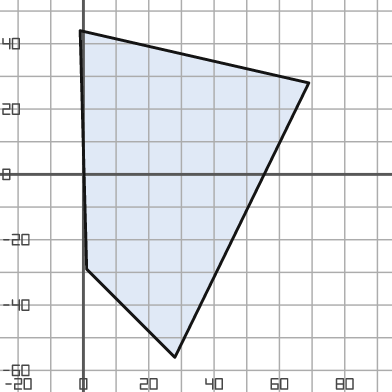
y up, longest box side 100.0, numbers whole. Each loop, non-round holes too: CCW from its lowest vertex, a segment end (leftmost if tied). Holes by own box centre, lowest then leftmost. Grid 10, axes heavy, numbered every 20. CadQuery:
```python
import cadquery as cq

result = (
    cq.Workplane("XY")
    .moveTo(28.0, -56.0)
    .lineTo(69.0, 28.0)
    .lineTo(-1.0, 44.0)
    .lineTo(1.0, -29.0)
    .close()
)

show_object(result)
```